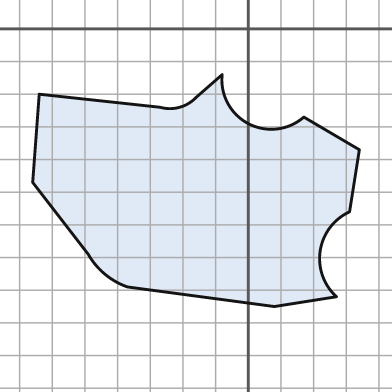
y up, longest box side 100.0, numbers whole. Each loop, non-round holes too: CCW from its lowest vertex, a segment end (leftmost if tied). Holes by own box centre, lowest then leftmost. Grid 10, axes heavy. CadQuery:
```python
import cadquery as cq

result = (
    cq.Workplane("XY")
    .moveTo(8.0, -85.0)
    .lineTo(27.0, -82.0)
    .threePointArc((22.0, -68.0), (31.0, -56.0))
    .lineTo(34.0, -37.0)
    .lineTo(17.0, -27.0)
    .threePointArc((0.0, -29.0), (-8.0, -14.0))
    .lineTo(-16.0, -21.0)
    .threePointArc((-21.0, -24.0), (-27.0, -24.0))
    .lineTo(-64.0, -20.0)
    .lineTo(-66.0, -47.0)
    .lineTo(-49.0, -69.0)
    .threePointArc((-44.0, -75.0), (-37.0, -79.0))
    .close()
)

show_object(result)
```